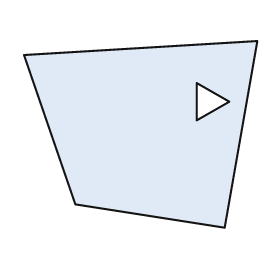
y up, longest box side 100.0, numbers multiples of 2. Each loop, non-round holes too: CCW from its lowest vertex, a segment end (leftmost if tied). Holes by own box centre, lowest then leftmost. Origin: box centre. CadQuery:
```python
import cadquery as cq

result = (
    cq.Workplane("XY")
    .moveTo(36.0, -40.0)
    .lineTo(50.0, 40.0)
    .lineTo(-50.0, 34.0)
    .lineTo(-28.0, -30.0)
    .close()
    .moveTo(24.0, 6.0)
    .lineTo(38.0, 14.0)
    .lineTo(24.0, 22.0)
    .close()
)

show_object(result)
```